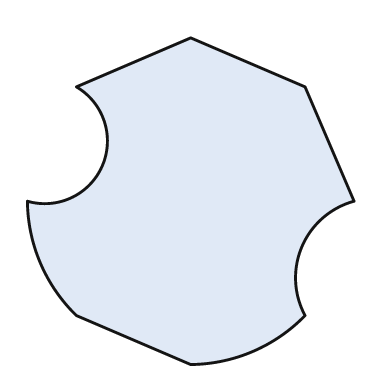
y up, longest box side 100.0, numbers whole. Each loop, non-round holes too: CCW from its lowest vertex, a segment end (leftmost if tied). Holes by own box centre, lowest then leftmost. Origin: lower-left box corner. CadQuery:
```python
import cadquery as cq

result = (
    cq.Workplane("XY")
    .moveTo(50.0, 0.0)
    .threePointArc((69.0, 4.0), (85.0, 15.0))
    .threePointArc((84.0, 36.0), (100.0, 50.0))
    .lineTo(85.0, 85.0)
    .lineTo(50.0, 100.0)
    .lineTo(15.0, 85.0)
    .threePointArc((23.0, 61.0), (0.0, 50.0))
    .threePointArc((4.0, 31.0), (15.0, 15.0))
    .close()
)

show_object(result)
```